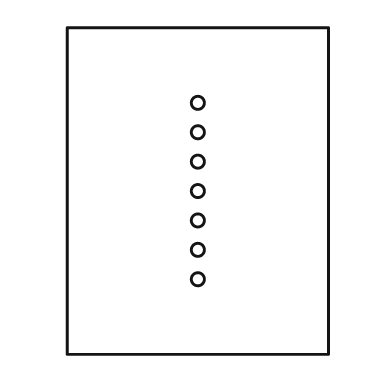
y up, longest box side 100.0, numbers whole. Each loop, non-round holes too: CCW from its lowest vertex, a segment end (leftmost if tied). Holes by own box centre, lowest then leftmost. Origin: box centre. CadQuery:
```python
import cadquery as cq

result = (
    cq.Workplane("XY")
    .moveTo(-40.0, -50.0)
    .lineTo(40.0, -50.0)
    .lineTo(40.0, 50.0)
    .lineTo(-40.0, 50.0)
    .close()
    .moveTo(0.0, -27.0)
    .circle(2.0)
    .moveTo(0.0, -18.0)
    .circle(2.0)
    .moveTo(0.0, -9.0)
    .circle(2.0)
    .moveTo(0.0, 0.0)
    .circle(2.0)
    .moveTo(0.0, 9.0)
    .circle(2.0)
    .moveTo(0.0, 18.0)
    .circle(2.0)
    .moveTo(0.0, 27.0)
    .circle(2.0)
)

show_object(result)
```